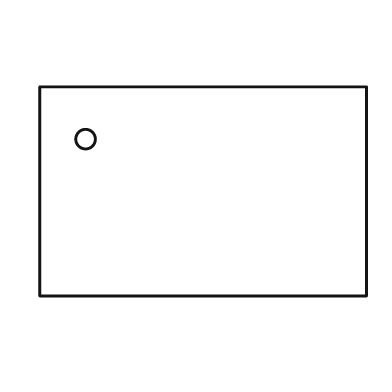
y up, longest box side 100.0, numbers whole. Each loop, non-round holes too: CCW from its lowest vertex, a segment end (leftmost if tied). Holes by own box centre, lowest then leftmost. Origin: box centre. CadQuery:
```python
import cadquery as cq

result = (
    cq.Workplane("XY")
    .moveTo(-50.0, -32.0)
    .lineTo(50.0, -32.0)
    .lineTo(50.0, 32.0)
    .lineTo(-50.0, 32.0)
    .close()
    .moveTo(-36.0, 16.0)
    .circle(3.0)
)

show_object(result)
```